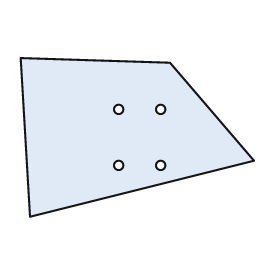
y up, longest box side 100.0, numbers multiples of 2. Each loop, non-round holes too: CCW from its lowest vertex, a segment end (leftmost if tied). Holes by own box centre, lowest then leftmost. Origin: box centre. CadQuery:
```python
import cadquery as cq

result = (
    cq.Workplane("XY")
    .moveTo(-46.0, -34.0)
    .lineTo(50.0, -10.0)
    .lineTo(14.0, 32.0)
    .lineTo(-50.0, 34.0)
    .close()
    .moveTo(-8.0, -12.0)
    .circle(2.0)
    .moveTo(10.0, -12.0)
    .circle(2.0)
    .moveTo(-8.0, 12.0)
    .circle(2.0)
    .moveTo(10.0, 12.0)
    .circle(2.0)
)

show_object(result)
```